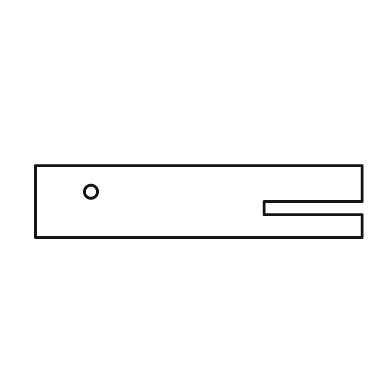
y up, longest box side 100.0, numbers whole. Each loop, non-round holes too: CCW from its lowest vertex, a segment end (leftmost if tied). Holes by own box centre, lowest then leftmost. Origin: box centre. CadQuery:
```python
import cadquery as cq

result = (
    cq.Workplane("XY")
    .moveTo(-50.0, -11.0)
    .lineTo(50.0, -11.0)
    .lineTo(50.0, -4.0)
    .lineTo(20.0, -4.0)
    .lineTo(20.0, 0.0)
    .lineTo(50.0, 0.0)
    .lineTo(50.0, 11.0)
    .lineTo(-50.0, 11.0)
    .close()
    .moveTo(-33.0, 3.0)
    .circle(2.0)
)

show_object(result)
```